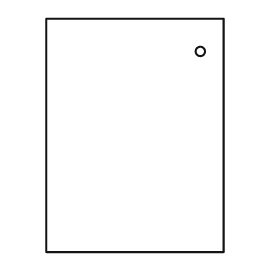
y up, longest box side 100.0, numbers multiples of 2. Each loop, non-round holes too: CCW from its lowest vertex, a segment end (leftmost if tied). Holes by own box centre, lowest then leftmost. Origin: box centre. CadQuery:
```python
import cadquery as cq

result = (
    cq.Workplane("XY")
    .moveTo(-38.0, -50.0)
    .lineTo(38.0, -50.0)
    .lineTo(38.0, 50.0)
    .lineTo(-38.0, 50.0)
    .close()
    .moveTo(28.0, 36.0)
    .circle(2.0)
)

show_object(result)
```